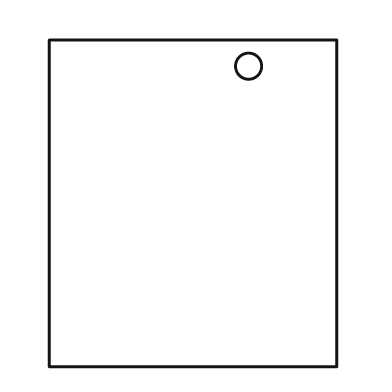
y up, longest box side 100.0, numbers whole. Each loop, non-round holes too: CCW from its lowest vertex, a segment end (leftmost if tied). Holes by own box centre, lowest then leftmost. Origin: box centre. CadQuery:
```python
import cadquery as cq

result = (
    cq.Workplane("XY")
    .moveTo(-44.0, -50.0)
    .lineTo(44.0, -50.0)
    .lineTo(44.0, 50.0)
    .lineTo(-44.0, 50.0)
    .close()
    .moveTo(17.0, 42.0)
    .circle(4.0)
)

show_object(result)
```